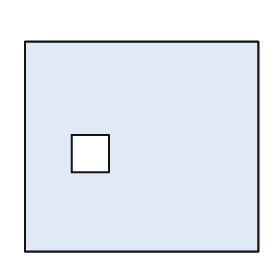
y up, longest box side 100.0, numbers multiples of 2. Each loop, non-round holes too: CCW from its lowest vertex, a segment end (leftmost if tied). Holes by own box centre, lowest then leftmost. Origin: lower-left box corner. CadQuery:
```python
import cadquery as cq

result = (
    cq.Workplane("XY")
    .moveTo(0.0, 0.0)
    .lineTo(100.0, 0.0)
    .lineTo(100.0, 90.0)
    .lineTo(0.0, 90.0)
    .close()
    .moveTo(20.0, 34.0)
    .lineTo(36.0, 34.0)
    .lineTo(36.0, 50.0)
    .lineTo(20.0, 50.0)
    .close()
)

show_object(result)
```